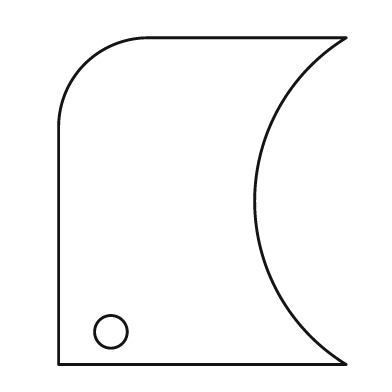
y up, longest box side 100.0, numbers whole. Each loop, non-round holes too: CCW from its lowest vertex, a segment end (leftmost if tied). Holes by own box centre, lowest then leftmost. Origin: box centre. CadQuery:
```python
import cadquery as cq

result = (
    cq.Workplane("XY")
    .moveTo(-44.0, -50.0)
    .lineTo(44.0, -50.0)
    .threePointArc((16.0, 0.0), (44.0, 50.0))
    .lineTo(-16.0, 50.0)
    .threePointArc((-36.0, 42.0), (-44.0, 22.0))
    .close()
    .moveTo(-28.0, -40.0)
    .circle(5.0)
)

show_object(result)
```